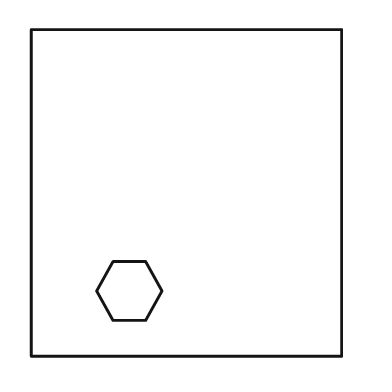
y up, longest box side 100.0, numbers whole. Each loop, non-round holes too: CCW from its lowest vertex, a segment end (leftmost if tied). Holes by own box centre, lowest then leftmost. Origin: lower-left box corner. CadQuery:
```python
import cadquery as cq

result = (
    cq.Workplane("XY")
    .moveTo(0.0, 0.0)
    .lineTo(95.0, 0.0)
    .lineTo(95.0, 100.0)
    .lineTo(0.0, 100.0)
    .close()
    .moveTo(25.0, 11.0)
    .lineTo(35.0, 11.0)
    .lineTo(40.0, 20.0)
    .lineTo(35.0, 29.0)
    .lineTo(25.0, 29.0)
    .lineTo(20.0, 20.0)
    .close()
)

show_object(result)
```